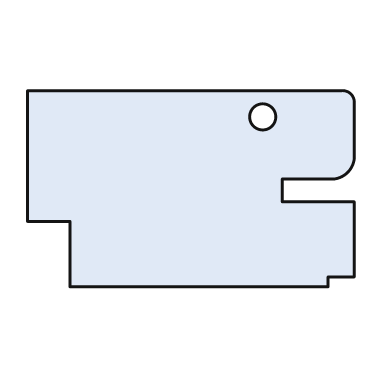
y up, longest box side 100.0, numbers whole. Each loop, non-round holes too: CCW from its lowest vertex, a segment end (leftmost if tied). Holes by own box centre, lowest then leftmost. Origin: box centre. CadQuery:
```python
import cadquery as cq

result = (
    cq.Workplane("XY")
    .moveTo(-37.0, -30.0)
    .lineTo(42.0, -30.0)
    .lineTo(42.0, -27.0)
    .lineTo(50.0, -27.0)
    .lineTo(50.0, -4.0)
    .lineTo(28.0, -4.0)
    .lineTo(28.0, 3.0)
    .lineTo(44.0, 3.0)
    .threePointArc((48.0, 5.0), (50.0, 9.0))
    .lineTo(50.0, 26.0)
    .threePointArc((49.0, 29.0), (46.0, 30.0))
    .lineTo(-50.0, 30.0)
    .lineTo(-50.0, -10.0)
    .lineTo(-37.0, -10.0)
    .close()
    .moveTo(22.0, 22.0)
    .circle(4.0)
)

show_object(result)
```